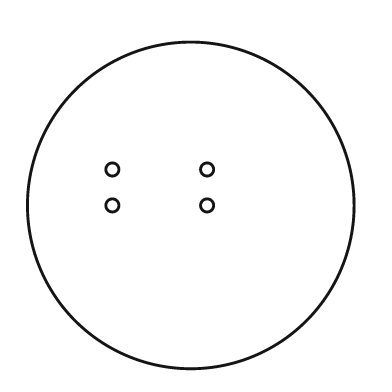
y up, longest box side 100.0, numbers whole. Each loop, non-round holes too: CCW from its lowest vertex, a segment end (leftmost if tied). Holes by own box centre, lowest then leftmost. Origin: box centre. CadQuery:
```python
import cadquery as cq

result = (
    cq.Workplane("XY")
    .moveTo(0.0, 0.0)
    .circle(50.0)
    .moveTo(-24.0, 0.0)
    .circle(2.0)
    .moveTo(5.0, 0.0)
    .circle(2.0)
    .moveTo(-24.0, 11.0)
    .circle(2.0)
    .moveTo(5.0, 11.0)
    .circle(2.0)
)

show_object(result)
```